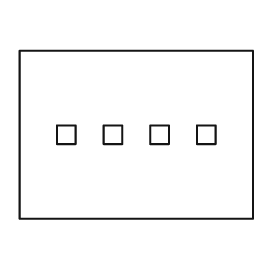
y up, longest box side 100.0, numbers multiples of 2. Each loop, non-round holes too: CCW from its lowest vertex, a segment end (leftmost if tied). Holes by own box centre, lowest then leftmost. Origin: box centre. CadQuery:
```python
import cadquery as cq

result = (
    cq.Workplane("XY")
    .moveTo(-50.0, -36.0)
    .lineTo(50.0, -36.0)
    .lineTo(50.0, 36.0)
    .lineTo(-50.0, 36.0)
    .close()
    .moveTo(-34.0, -4.0)
    .lineTo(-26.0, -4.0)
    .lineTo(-26.0, 4.0)
    .lineTo(-34.0, 4.0)
    .close()
    .moveTo(-14.0, -4.0)
    .lineTo(-6.0, -4.0)
    .lineTo(-6.0, 4.0)
    .lineTo(-14.0, 4.0)
    .close()
    .moveTo(6.0, -4.0)
    .lineTo(14.0, -4.0)
    .lineTo(14.0, 4.0)
    .lineTo(6.0, 4.0)
    .close()
    .moveTo(26.0, -4.0)
    .lineTo(34.0, -4.0)
    .lineTo(34.0, 4.0)
    .lineTo(26.0, 4.0)
    .close()
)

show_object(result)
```